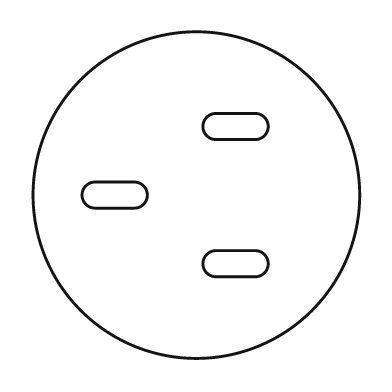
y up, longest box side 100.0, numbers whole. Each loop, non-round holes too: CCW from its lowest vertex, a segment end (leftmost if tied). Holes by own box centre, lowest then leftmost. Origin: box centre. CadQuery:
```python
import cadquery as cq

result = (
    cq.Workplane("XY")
    .moveTo(0.0, 0.0)
    .circle(50.0)
    .moveTo(6.0, -25.0)
    .lineTo(18.0, -25.0)
    .threePointArc((22.0, -21.0), (18.0, -17.0))
    .lineTo(6.0, -17.0)
    .threePointArc((2.0, -21.0), (6.0, -25.0))
    .close()
    .moveTo(-31.0, -4.0)
    .lineTo(-19.0, -4.0)
    .threePointArc((-15.0, 0.0), (-19.0, 4.0))
    .lineTo(-31.0, 4.0)
    .threePointArc((-35.0, 0.0), (-31.0, -4.0))
    .close()
    .moveTo(6.0, 17.0)
    .lineTo(18.0, 17.0)
    .threePointArc((22.0, 21.0), (18.0, 25.0))
    .lineTo(6.0, 25.0)
    .threePointArc((2.0, 21.0), (6.0, 17.0))
    .close()
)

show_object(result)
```